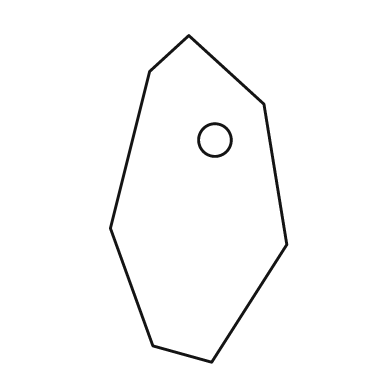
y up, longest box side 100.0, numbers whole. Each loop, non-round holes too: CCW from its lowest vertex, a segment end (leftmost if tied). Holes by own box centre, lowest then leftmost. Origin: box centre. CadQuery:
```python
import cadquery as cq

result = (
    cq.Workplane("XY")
    .moveTo(4.0, -50.0)
    .lineTo(27.0, -14.0)
    .lineTo(20.0, 29.0)
    .lineTo(-3.0, 50.0)
    .lineTo(-15.0, 39.0)
    .lineTo(-27.0, -9.0)
    .lineTo(-14.0, -45.0)
    .close()
    .moveTo(5.0, 18.0)
    .circle(5.0)
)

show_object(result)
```